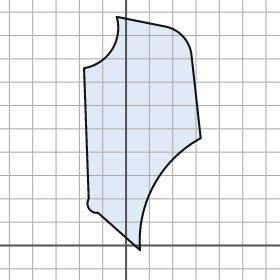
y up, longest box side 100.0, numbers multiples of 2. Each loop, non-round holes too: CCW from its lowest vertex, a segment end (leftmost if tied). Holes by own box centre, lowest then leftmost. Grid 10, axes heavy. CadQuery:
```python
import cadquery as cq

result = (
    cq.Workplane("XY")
    .moveTo(6.0, -2.0)
    .threePointArc((12.0, 26.0), (32.0, 46.0))
    .lineTo(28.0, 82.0)
    .threePointArc((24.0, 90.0), (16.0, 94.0))
    .lineTo(-4.0, 98.0)
    .threePointArc((-6.0, 84.0), (-18.0, 76.0))
    .lineTo(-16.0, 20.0)
    .threePointArc((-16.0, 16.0), (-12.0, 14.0))
    .close()
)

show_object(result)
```